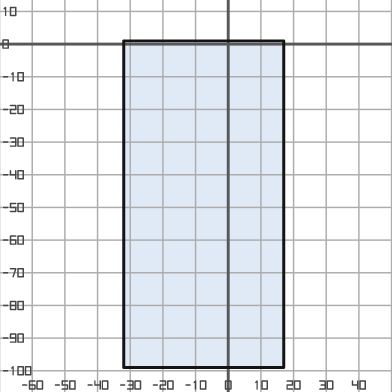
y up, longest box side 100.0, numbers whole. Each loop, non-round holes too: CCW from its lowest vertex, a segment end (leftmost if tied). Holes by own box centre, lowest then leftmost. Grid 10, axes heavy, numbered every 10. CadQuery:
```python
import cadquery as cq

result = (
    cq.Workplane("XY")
    .moveTo(-32.0, -99.0)
    .lineTo(17.0, -99.0)
    .lineTo(17.0, 1.0)
    .lineTo(-32.0, 1.0)
    .close()
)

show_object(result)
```